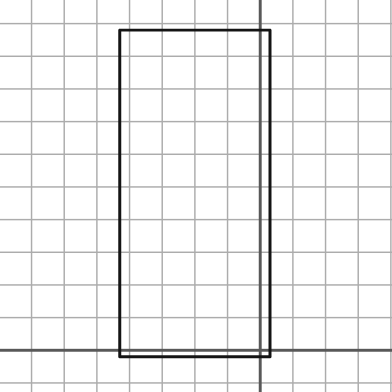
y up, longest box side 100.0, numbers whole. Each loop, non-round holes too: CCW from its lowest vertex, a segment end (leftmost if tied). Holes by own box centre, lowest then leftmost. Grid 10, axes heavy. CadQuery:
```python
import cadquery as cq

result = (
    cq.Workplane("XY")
    .moveTo(-43.0, -2.0)
    .lineTo(3.0, -2.0)
    .lineTo(3.0, 98.0)
    .lineTo(-43.0, 98.0)
    .close()
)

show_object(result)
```